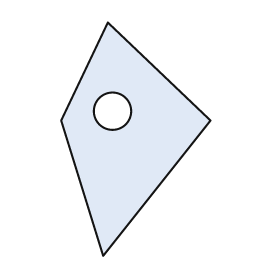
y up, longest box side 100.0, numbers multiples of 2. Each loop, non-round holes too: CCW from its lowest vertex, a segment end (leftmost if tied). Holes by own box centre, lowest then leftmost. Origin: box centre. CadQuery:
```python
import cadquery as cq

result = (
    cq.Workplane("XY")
    .moveTo(-14.0, -50.0)
    .lineTo(32.0, 8.0)
    .lineTo(-12.0, 50.0)
    .lineTo(-32.0, 8.0)
    .close()
    .moveTo(-10.0, 12.0)
    .circle(8.0)
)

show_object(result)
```